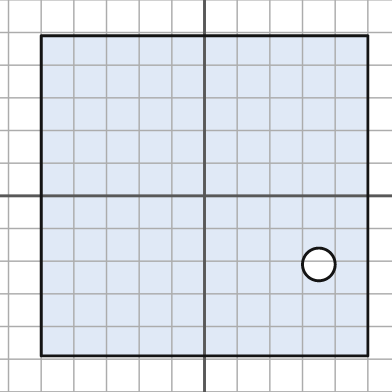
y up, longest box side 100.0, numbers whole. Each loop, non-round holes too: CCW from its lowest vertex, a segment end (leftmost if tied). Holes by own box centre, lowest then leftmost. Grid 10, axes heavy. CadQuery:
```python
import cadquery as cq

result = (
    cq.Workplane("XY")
    .moveTo(-50.0, -49.0)
    .lineTo(50.0, -49.0)
    .lineTo(50.0, 49.0)
    .lineTo(-50.0, 49.0)
    .close()
    .moveTo(35.0, -21.0)
    .circle(5.0)
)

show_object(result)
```